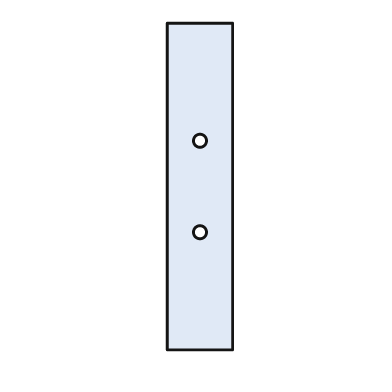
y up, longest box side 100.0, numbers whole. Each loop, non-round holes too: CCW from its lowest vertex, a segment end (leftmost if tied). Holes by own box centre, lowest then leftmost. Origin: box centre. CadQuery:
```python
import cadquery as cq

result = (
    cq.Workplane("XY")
    .moveTo(-10.0, -50.0)
    .lineTo(10.0, -50.0)
    .lineTo(10.0, 50.0)
    .lineTo(-10.0, 50.0)
    .close()
    .moveTo(0.0, -14.0)
    .circle(2.0)
    .moveTo(0.0, 14.0)
    .circle(2.0)
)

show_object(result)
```